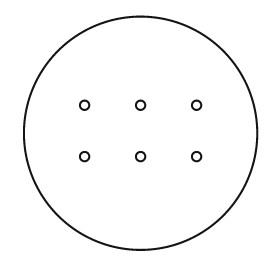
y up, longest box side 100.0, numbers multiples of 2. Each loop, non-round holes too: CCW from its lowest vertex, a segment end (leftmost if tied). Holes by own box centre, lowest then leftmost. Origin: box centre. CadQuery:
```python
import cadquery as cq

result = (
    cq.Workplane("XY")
    .moveTo(0.0, 0.0)
    .circle(50.0)
    .moveTo(-24.0, -10.0)
    .circle(2.0)
    .moveTo(0.0, -10.0)
    .circle(2.0)
    .moveTo(24.0, -10.0)
    .circle(2.0)
    .moveTo(-24.0, 12.0)
    .circle(2.0)
    .moveTo(0.0, 12.0)
    .circle(2.0)
    .moveTo(24.0, 12.0)
    .circle(2.0)
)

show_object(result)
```